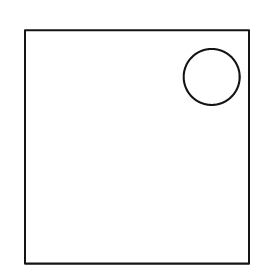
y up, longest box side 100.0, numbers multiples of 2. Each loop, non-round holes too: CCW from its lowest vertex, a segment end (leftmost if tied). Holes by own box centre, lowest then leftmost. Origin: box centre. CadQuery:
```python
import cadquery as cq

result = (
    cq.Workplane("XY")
    .moveTo(-48.0, -50.0)
    .lineTo(48.0, -50.0)
    .lineTo(48.0, 50.0)
    .lineTo(-48.0, 50.0)
    .close()
    .moveTo(32.0, 30.0)
    .circle(12.0)
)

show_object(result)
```